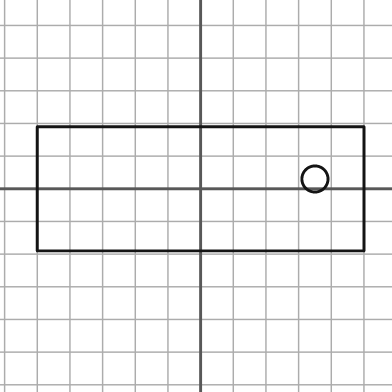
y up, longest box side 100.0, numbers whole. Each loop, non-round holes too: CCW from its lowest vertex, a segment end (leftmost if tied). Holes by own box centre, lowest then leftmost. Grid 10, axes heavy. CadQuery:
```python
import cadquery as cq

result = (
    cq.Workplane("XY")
    .moveTo(-50.0, -19.0)
    .lineTo(50.0, -19.0)
    .lineTo(50.0, 19.0)
    .lineTo(-50.0, 19.0)
    .close()
    .moveTo(35.0, 3.0)
    .circle(4.0)
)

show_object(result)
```